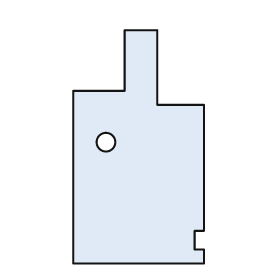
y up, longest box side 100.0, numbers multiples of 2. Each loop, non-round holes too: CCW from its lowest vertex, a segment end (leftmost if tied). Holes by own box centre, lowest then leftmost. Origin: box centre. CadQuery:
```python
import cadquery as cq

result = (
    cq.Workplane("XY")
    .moveTo(-28.0, -50.0)
    .lineTo(28.0, -50.0)
    .lineTo(28.0, -44.0)
    .lineTo(24.0, -44.0)
    .lineTo(24.0, -36.0)
    .lineTo(28.0, -36.0)
    .lineTo(28.0, 18.0)
    .lineTo(8.0, 18.0)
    .lineTo(8.0, 50.0)
    .lineTo(-6.0, 50.0)
    .lineTo(-6.0, 24.0)
    .lineTo(-28.0, 24.0)
    .close()
    .moveTo(-14.0, 2.0)
    .circle(4.0)
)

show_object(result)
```